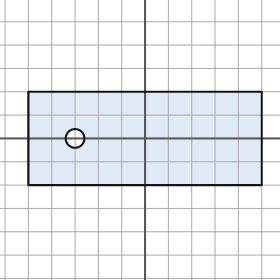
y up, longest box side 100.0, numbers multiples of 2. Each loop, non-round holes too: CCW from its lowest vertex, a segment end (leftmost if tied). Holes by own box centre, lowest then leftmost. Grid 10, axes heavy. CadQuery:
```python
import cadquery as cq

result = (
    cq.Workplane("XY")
    .moveTo(-50.0, -20.0)
    .lineTo(50.0, -20.0)
    .lineTo(50.0, 20.0)
    .lineTo(-50.0, 20.0)
    .close()
    .moveTo(-30.0, 0.0)
    .circle(4.0)
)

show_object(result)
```